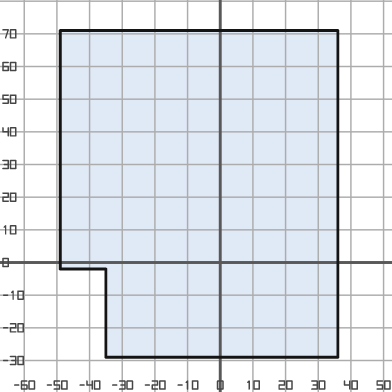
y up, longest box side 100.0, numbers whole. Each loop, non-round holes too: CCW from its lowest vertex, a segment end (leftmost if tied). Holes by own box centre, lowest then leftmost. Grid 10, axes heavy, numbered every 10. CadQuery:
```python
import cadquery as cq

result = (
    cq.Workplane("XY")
    .moveTo(-35.0, -29.0)
    .lineTo(36.0, -29.0)
    .lineTo(36.0, 71.0)
    .lineTo(-49.0, 71.0)
    .lineTo(-49.0, -2.0)
    .lineTo(-35.0, -2.0)
    .close()
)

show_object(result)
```